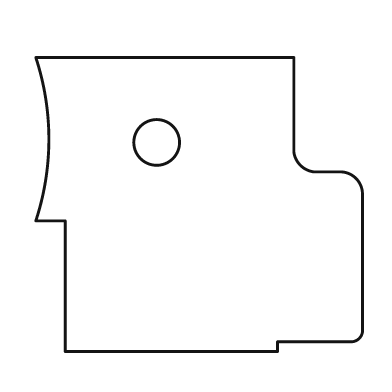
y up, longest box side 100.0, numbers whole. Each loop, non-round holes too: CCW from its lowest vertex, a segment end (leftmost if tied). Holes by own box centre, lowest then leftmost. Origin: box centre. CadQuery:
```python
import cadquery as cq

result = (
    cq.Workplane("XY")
    .moveTo(-41.0, -45.0)
    .lineTo(24.0, -45.0)
    .lineTo(24.0, -42.0)
    .lineTo(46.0, -42.0)
    .threePointArc((49.0, -41.0), (50.0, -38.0))
    .lineTo(50.0, 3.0)
    .threePointArc((48.0, 8.0), (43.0, 10.0))
    .lineTo(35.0, 10.0)
    .threePointArc((31.0, 12.0), (29.0, 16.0))
    .lineTo(29.0, 45.0)
    .lineTo(-50.0, 45.0)
    .threePointArc((-46.0, 20.0), (-50.0, -5.0))
    .lineTo(-41.0, -5.0)
    .close()
    .moveTo(-13.0, 19.0)
    .circle(7.0)
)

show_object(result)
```